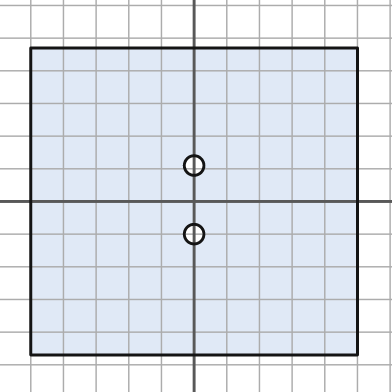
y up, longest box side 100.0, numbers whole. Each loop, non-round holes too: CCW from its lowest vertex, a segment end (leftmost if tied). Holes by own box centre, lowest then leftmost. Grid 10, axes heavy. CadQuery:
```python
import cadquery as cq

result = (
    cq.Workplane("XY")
    .moveTo(-50.0, -47.0)
    .lineTo(50.0, -47.0)
    .lineTo(50.0, 47.0)
    .lineTo(-50.0, 47.0)
    .close()
    .moveTo(0.0, -10.0)
    .circle(3.0)
    .moveTo(0.0, 11.0)
    .circle(3.0)
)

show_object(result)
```